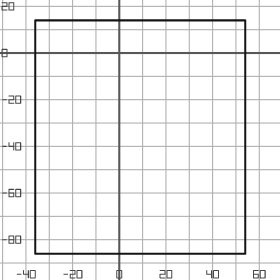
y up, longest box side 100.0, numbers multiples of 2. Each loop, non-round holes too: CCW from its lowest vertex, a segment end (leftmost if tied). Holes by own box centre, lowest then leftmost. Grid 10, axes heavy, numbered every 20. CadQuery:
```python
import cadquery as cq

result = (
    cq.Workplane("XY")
    .moveTo(-36.0, -86.0)
    .lineTo(54.0, -86.0)
    .lineTo(54.0, 14.0)
    .lineTo(-36.0, 14.0)
    .close()
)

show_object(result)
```